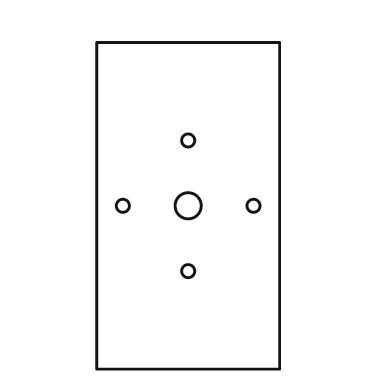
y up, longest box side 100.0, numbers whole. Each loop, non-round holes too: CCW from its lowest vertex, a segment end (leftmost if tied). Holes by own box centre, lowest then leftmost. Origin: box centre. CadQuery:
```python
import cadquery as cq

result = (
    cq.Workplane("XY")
    .moveTo(-28.0, -50.0)
    .lineTo(28.0, -50.0)
    .lineTo(28.0, 50.0)
    .lineTo(-28.0, 50.0)
    .close()
    .moveTo(0.0, -20.0)
    .circle(2.0)
    .moveTo(-20.0, 0.0)
    .circle(2.0)
    .moveTo(0.0, 0.0)
    .circle(4.0)
    .moveTo(20.0, 0.0)
    .circle(2.0)
    .moveTo(0.0, 20.0)
    .circle(2.0)
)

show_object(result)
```